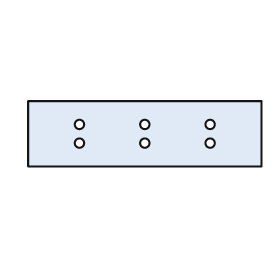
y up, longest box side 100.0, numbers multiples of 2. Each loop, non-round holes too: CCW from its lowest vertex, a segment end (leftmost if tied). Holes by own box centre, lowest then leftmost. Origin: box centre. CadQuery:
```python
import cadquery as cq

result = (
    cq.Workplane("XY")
    .moveTo(-50.0, -14.0)
    .lineTo(50.0, -14.0)
    .lineTo(50.0, 14.0)
    .lineTo(-50.0, 14.0)
    .close()
    .moveTo(-28.0, -4.0)
    .circle(2.0)
    .moveTo(0.0, -4.0)
    .circle(2.0)
    .moveTo(28.0, -4.0)
    .circle(2.0)
    .moveTo(-28.0, 4.0)
    .circle(2.0)
    .moveTo(0.0, 4.0)
    .circle(2.0)
    .moveTo(28.0, 4.0)
    .circle(2.0)
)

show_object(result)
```